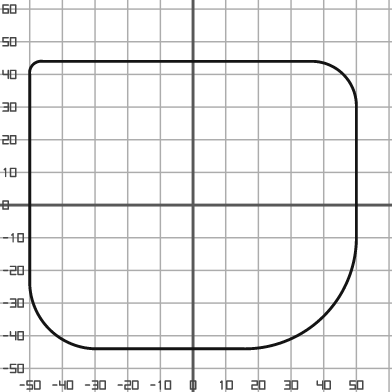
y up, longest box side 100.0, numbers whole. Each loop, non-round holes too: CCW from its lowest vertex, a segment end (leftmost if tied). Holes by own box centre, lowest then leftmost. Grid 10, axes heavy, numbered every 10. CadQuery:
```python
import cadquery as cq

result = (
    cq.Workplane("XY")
    .moveTo(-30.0, -44.0)
    .lineTo(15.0, -44.0)
    .threePointArc((40.0, -34.0), (50.0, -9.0))
    .lineTo(50.0, 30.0)
    .threePointArc((46.0, 40.0), (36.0, 44.0))
    .lineTo(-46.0, 44.0)
    .threePointArc((-49.0, 43.0), (-50.0, 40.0))
    .lineTo(-50.0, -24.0)
    .threePointArc((-44.0, -38.0), (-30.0, -44.0))
    .close()
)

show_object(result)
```